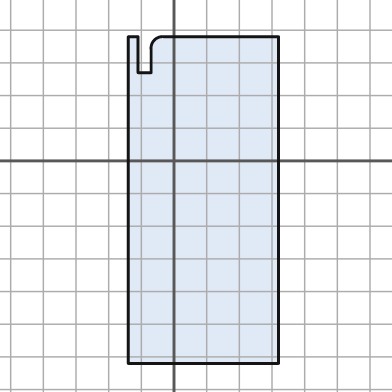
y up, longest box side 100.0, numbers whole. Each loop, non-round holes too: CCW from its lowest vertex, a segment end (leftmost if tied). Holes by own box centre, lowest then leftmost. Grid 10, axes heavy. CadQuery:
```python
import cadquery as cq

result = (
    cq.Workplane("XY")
    .moveTo(-14.0, -62.0)
    .lineTo(32.0, -62.0)
    .lineTo(32.0, 38.0)
    .lineTo(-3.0, 38.0)
    .threePointArc((-6.0, 37.0), (-7.0, 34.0))
    .lineTo(-7.0, 27.0)
    .lineTo(-11.0, 27.0)
    .lineTo(-11.0, 38.0)
    .lineTo(-14.0, 38.0)
    .close()
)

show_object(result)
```